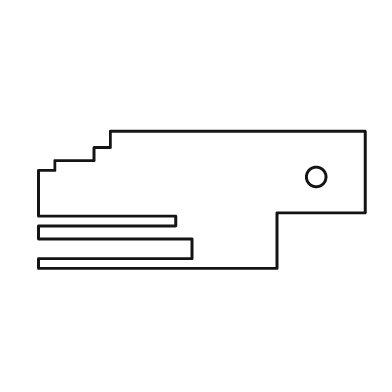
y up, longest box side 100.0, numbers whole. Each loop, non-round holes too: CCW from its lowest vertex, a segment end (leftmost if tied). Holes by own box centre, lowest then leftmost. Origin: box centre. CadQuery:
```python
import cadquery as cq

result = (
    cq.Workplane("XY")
    .moveTo(-50.0, -21.0)
    .lineTo(23.0, -21.0)
    .lineTo(23.0, -4.0)
    .lineTo(50.0, -4.0)
    .lineTo(50.0, 21.0)
    .lineTo(-28.0, 21.0)
    .lineTo(-28.0, 16.0)
    .lineTo(-33.0, 16.0)
    .lineTo(-33.0, 12.0)
    .lineTo(-45.0, 12.0)
    .lineTo(-45.0, 9.0)
    .lineTo(-50.0, 9.0)
    .lineTo(-50.0, -5.0)
    .lineTo(-8.0, -5.0)
    .lineTo(-8.0, -8.0)
    .lineTo(-50.0, -8.0)
    .lineTo(-50.0, -12.0)
    .lineTo(-3.0, -12.0)
    .lineTo(-3.0, -18.0)
    .lineTo(-50.0, -18.0)
    .close()
    .moveTo(35.0, 7.0)
    .circle(3.0)
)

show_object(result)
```